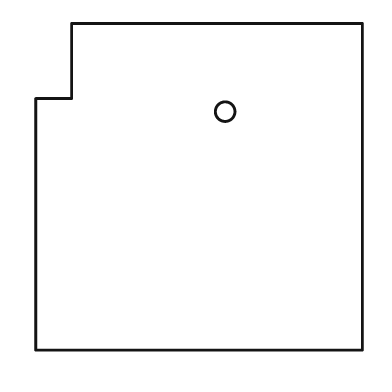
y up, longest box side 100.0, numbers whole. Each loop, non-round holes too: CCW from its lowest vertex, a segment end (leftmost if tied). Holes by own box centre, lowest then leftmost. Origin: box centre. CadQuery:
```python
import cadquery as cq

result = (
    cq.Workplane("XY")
    .moveTo(-50.0, -50.0)
    .lineTo(50.0, -50.0)
    .lineTo(50.0, 50.0)
    .lineTo(-39.0, 50.0)
    .lineTo(-39.0, 27.0)
    .lineTo(-50.0, 27.0)
    .close()
    .moveTo(8.0, 23.0)
    .circle(3.0)
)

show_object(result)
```